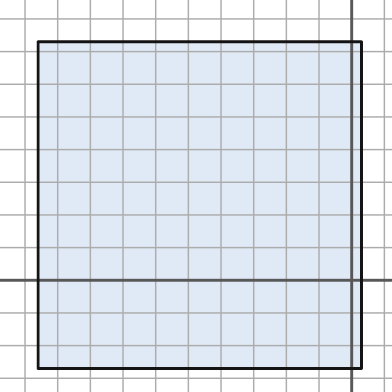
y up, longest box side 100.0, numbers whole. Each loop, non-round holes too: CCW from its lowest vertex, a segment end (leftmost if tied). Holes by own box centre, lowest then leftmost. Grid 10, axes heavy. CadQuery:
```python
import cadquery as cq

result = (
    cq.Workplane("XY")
    .moveTo(-96.0, -27.0)
    .lineTo(3.0, -27.0)
    .lineTo(3.0, 73.0)
    .lineTo(-96.0, 73.0)
    .close()
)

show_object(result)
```